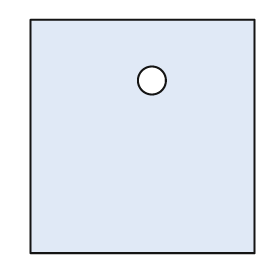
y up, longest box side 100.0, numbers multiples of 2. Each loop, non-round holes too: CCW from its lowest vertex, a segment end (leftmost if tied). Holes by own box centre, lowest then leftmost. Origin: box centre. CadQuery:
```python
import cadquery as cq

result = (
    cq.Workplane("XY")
    .moveTo(-48.0, -50.0)
    .lineTo(48.0, -50.0)
    .lineTo(48.0, 50.0)
    .lineTo(-48.0, 50.0)
    .close()
    .moveTo(4.0, 24.0)
    .circle(6.0)
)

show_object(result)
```